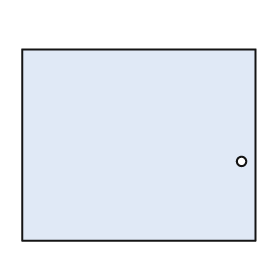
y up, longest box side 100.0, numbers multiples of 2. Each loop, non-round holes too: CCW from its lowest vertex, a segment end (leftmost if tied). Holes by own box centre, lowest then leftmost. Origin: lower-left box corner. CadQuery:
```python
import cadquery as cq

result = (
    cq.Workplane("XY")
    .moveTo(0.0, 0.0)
    .lineTo(100.0, 0.0)
    .lineTo(100.0, 82.0)
    .lineTo(0.0, 82.0)
    .close()
    .moveTo(94.0, 34.0)
    .circle(2.0)
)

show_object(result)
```